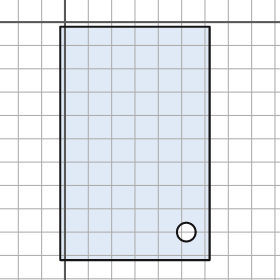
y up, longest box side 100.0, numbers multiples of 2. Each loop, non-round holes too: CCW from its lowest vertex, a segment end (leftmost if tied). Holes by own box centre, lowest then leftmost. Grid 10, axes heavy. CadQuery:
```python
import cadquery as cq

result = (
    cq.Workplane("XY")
    .moveTo(-2.0, -102.0)
    .lineTo(62.0, -102.0)
    .lineTo(62.0, -2.0)
    .lineTo(-2.0, -2.0)
    .close()
    .moveTo(52.0, -90.0)
    .circle(4.0)
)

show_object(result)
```